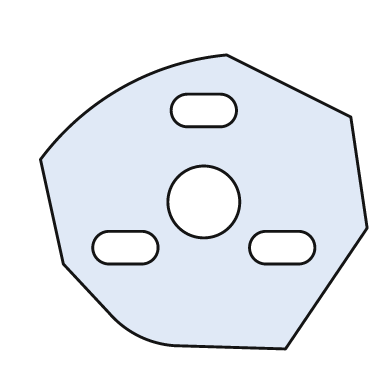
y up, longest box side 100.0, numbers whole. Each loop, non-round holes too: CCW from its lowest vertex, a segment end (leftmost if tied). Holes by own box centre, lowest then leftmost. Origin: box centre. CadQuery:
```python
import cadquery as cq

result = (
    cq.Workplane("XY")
    .moveTo(25.0, -45.0)
    .lineTo(50.0, -8.0)
    .lineTo(45.0, 26.0)
    .lineTo(7.0, 45.0)
    .threePointArc((-25.0, 35.0), (-50.0, 13.0))
    .lineTo(-43.0, -19.0)
    .lineTo(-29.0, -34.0)
    .threePointArc((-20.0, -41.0), (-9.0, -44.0))
    .close()
    .moveTo(-29.0, -19.0)
    .lineTo(-19.0, -19.0)
    .threePointArc((-14.0, -14.0), (-19.0, -9.0))
    .lineTo(-29.0, -9.0)
    .threePointArc((-34.0, -14.0), (-29.0, -19.0))
    .close()
    .moveTo(19.0, -19.0)
    .lineTo(29.0, -19.0)
    .threePointArc((34.0, -14.0), (29.0, -9.0))
    .lineTo(19.0, -9.0)
    .threePointArc((14.0, -14.0), (19.0, -19.0))
    .close()
    .moveTo(0.0, 0.0)
    .circle(11.0)
    .moveTo(-5.0, 23.0)
    .lineTo(5.0, 23.0)
    .threePointArc((10.0, 28.0), (5.0, 33.0))
    .lineTo(-5.0, 33.0)
    .threePointArc((-10.0, 28.0), (-5.0, 23.0))
    .close()
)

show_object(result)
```